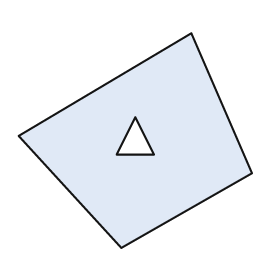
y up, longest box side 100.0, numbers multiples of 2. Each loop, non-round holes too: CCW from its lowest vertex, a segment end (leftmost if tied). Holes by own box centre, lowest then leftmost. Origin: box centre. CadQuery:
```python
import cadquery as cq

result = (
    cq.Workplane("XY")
    .moveTo(-6.0, -46.0)
    .lineTo(50.0, -14.0)
    .lineTo(24.0, 46.0)
    .lineTo(-50.0, 2.0)
    .close()
    .moveTo(-8.0, -6.0)
    .lineTo(8.0, -6.0)
    .lineTo(0.0, 10.0)
    .close()
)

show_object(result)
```